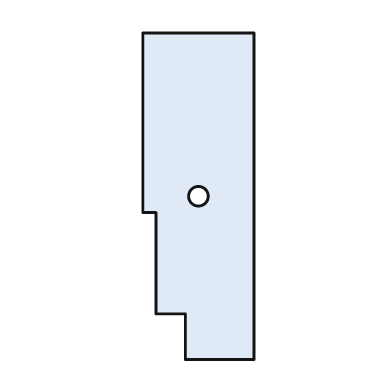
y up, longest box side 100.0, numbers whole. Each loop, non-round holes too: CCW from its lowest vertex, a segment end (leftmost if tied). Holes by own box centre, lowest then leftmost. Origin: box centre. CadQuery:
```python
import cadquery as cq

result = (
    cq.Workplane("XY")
    .moveTo(-4.0, -50.0)
    .lineTo(17.0, -50.0)
    .lineTo(17.0, 50.0)
    .lineTo(-17.0, 50.0)
    .lineTo(-17.0, -5.0)
    .lineTo(-13.0, -5.0)
    .lineTo(-13.0, -36.0)
    .lineTo(-4.0, -36.0)
    .close()
    .moveTo(0.0, 0.0)
    .circle(3.0)
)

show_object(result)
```